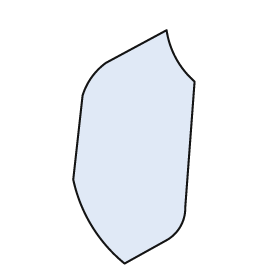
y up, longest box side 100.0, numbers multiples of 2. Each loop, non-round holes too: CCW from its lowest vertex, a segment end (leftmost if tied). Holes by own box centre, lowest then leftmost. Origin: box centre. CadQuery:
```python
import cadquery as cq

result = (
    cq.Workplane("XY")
    .moveTo(-4.0, -50.0)
    .lineTo(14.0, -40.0)
    .threePointArc((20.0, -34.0), (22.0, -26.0))
    .lineTo(26.0, 28.0)
    .threePointArc((18.0, 38.0), (14.0, 50.0))
    .lineTo(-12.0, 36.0)
    .threePointArc((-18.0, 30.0), (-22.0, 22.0))
    .lineTo(-26.0, -14.0)
    .threePointArc((-18.0, -34.0), (-4.0, -50.0))
    .close()
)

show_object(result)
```